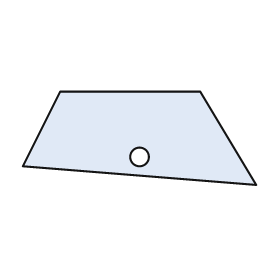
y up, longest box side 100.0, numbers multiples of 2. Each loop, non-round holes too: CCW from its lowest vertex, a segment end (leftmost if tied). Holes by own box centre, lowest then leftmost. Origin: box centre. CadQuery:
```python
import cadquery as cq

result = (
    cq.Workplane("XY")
    .moveTo(50.0, -20.0)
    .lineTo(26.0, 20.0)
    .lineTo(-34.0, 20.0)
    .lineTo(-50.0, -12.0)
    .close()
    .moveTo(0.0, -8.0)
    .circle(4.0)
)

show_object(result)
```